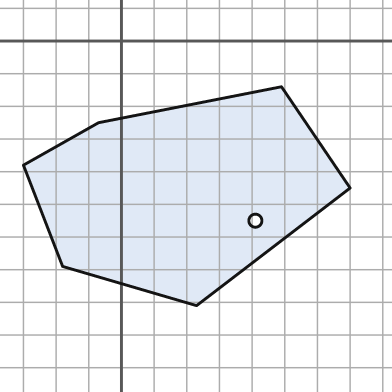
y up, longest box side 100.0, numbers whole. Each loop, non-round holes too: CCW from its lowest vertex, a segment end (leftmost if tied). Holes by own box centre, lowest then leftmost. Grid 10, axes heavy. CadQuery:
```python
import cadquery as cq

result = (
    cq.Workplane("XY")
    .moveTo(23.0, -81.0)
    .lineTo(70.0, -45.0)
    .lineTo(49.0, -14.0)
    .lineTo(-7.0, -25.0)
    .lineTo(-30.0, -38.0)
    .lineTo(-18.0, -69.0)
    .close()
    .moveTo(41.0, -55.0)
    .circle(2.0)
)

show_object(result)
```